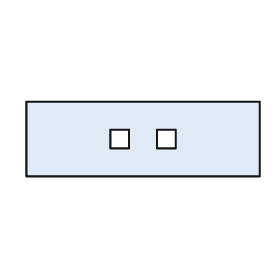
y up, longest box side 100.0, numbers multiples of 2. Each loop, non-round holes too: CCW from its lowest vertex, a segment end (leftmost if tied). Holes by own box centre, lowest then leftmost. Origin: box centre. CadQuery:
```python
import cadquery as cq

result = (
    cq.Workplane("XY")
    .moveTo(-50.0, -16.0)
    .lineTo(50.0, -16.0)
    .lineTo(50.0, 16.0)
    .lineTo(-50.0, 16.0)
    .close()
    .moveTo(-14.0, -4.0)
    .lineTo(-6.0, -4.0)
    .lineTo(-6.0, 4.0)
    .lineTo(-14.0, 4.0)
    .close()
    .moveTo(6.0, -4.0)
    .lineTo(14.0, -4.0)
    .lineTo(14.0, 4.0)
    .lineTo(6.0, 4.0)
    .close()
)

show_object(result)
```